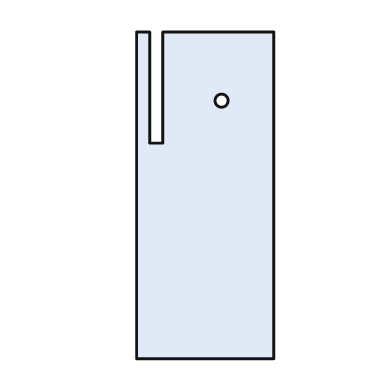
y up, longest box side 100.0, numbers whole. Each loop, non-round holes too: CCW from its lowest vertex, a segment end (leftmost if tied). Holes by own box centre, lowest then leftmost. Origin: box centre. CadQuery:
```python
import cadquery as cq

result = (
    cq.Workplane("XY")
    .moveTo(-21.0, -50.0)
    .lineTo(21.0, -50.0)
    .lineTo(21.0, 50.0)
    .lineTo(-13.0, 50.0)
    .lineTo(-13.0, 16.0)
    .lineTo(-17.0, 16.0)
    .lineTo(-17.0, 50.0)
    .lineTo(-21.0, 50.0)
    .close()
    .moveTo(5.0, 29.0)
    .circle(2.0)
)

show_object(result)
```